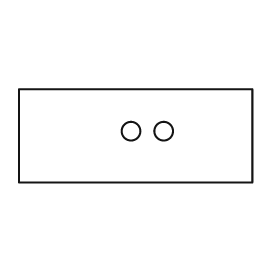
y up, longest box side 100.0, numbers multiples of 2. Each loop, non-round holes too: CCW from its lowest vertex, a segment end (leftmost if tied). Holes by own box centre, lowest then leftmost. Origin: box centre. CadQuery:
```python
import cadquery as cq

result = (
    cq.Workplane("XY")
    .moveTo(-50.0, -20.0)
    .lineTo(50.0, -20.0)
    .lineTo(50.0, 20.0)
    .lineTo(-50.0, 20.0)
    .close()
    .moveTo(-2.0, 2.0)
    .circle(4.0)
    .moveTo(12.0, 2.0)
    .circle(4.0)
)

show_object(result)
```